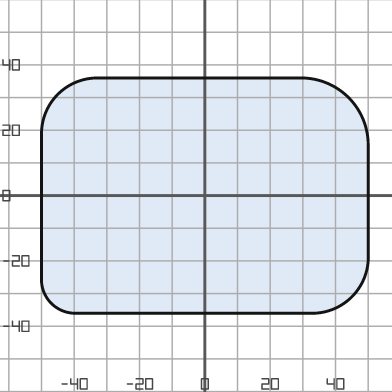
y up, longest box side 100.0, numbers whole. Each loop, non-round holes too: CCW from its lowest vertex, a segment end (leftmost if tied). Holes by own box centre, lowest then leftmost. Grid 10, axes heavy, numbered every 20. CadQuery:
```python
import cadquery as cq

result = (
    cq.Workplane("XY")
    .moveTo(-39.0, -36.0)
    .lineTo(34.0, -36.0)
    .threePointArc((45.0, -31.0), (50.0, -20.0))
    .lineTo(50.0, 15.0)
    .threePointArc((44.0, 30.0), (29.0, 36.0))
    .lineTo(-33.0, 36.0)
    .threePointArc((-45.0, 31.0), (-50.0, 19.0))
    .lineTo(-50.0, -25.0)
    .threePointArc((-47.0, -33.0), (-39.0, -36.0))
    .close()
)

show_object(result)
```